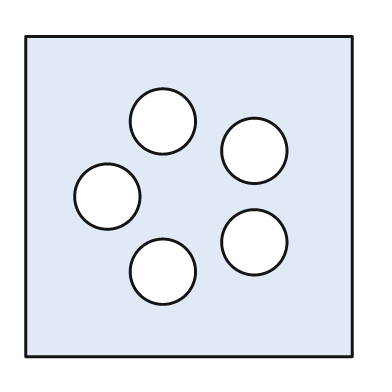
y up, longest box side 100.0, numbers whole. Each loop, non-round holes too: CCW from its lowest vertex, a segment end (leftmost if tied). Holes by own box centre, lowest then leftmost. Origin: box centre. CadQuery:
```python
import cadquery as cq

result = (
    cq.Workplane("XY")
    .moveTo(-50.0, -49.0)
    .lineTo(50.0, -49.0)
    .lineTo(50.0, 49.0)
    .lineTo(-50.0, 49.0)
    .close()
    .moveTo(-8.0, -23.0)
    .circle(10.0)
    .moveTo(20.0, -14.0)
    .circle(10.0)
    .moveTo(-25.0, 0.0)
    .circle(10.0)
    .moveTo(20.0, 14.0)
    .circle(10.0)
    .moveTo(-8.0, 23.0)
    .circle(10.0)
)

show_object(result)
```